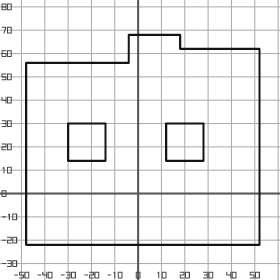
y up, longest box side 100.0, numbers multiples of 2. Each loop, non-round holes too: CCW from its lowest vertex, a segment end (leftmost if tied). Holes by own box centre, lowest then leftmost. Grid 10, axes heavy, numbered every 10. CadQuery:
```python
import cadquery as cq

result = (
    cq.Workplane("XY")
    .moveTo(-48.0, -22.0)
    .lineTo(52.0, -22.0)
    .lineTo(52.0, 62.0)
    .lineTo(18.0, 62.0)
    .lineTo(18.0, 68.0)
    .lineTo(-4.0, 68.0)
    .lineTo(-4.0, 56.0)
    .lineTo(-48.0, 56.0)
    .close()
    .moveTo(-30.0, 14.0)
    .lineTo(-14.0, 14.0)
    .lineTo(-14.0, 30.0)
    .lineTo(-30.0, 30.0)
    .close()
    .moveTo(12.0, 14.0)
    .lineTo(28.0, 14.0)
    .lineTo(28.0, 30.0)
    .lineTo(12.0, 30.0)
    .close()
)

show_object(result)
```